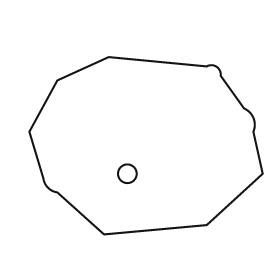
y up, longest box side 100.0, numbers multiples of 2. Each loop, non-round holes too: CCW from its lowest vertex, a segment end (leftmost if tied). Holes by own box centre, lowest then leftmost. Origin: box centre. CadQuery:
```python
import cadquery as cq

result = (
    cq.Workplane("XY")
    .moveTo(-18.0, -38.0)
    .lineTo(26.0, -34.0)
    .lineTo(50.0, -12.0)
    .lineTo(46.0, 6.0)
    .threePointArc((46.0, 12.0), (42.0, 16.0))
    .lineTo(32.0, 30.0)
    .threePointArc((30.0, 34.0), (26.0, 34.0))
    .lineTo(-16.0, 38.0)
    .lineTo(-38.0, 28.0)
    .lineTo(-50.0, 6.0)
    .lineTo(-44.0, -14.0)
    .threePointArc((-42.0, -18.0), (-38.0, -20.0))
    .close()
    .moveTo(-8.0, -12.0)
    .circle(4.0)
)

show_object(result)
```